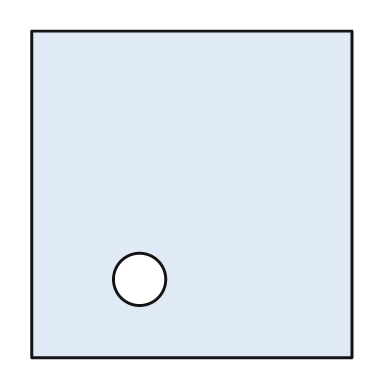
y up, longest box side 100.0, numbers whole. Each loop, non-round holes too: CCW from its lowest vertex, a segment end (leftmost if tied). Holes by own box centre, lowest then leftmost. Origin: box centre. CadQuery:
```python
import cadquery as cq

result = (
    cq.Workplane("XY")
    .moveTo(-49.0, -50.0)
    .lineTo(49.0, -50.0)
    .lineTo(49.0, 50.0)
    .lineTo(-49.0, 50.0)
    .close()
    .moveTo(-16.0, -26.0)
    .circle(8.0)
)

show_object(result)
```